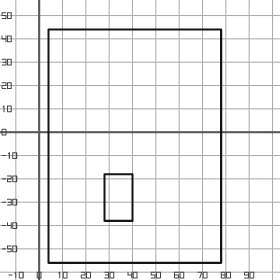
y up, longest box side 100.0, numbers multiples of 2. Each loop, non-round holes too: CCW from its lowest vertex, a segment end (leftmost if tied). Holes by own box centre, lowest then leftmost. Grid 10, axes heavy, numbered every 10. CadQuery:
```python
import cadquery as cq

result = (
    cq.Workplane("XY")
    .moveTo(4.0, -56.0)
    .lineTo(78.0, -56.0)
    .lineTo(78.0, 44.0)
    .lineTo(4.0, 44.0)
    .close()
    .moveTo(28.0, -38.0)
    .lineTo(40.0, -38.0)
    .lineTo(40.0, -18.0)
    .lineTo(28.0, -18.0)
    .close()
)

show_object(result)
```